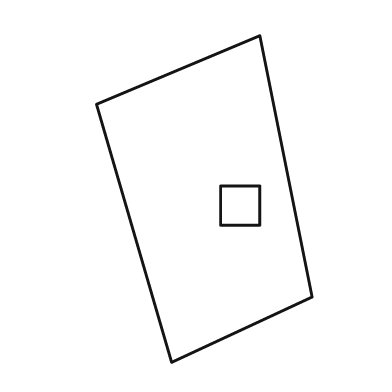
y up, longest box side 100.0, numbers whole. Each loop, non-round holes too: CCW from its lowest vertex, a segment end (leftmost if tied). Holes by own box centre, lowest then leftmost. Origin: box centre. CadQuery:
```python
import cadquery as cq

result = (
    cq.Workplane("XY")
    .moveTo(-10.0, -50.0)
    .lineTo(33.0, -30.0)
    .lineTo(17.0, 50.0)
    .lineTo(-33.0, 29.0)
    .close()
    .moveTo(5.0, -8.0)
    .lineTo(17.0, -8.0)
    .lineTo(17.0, 4.0)
    .lineTo(5.0, 4.0)
    .close()
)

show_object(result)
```